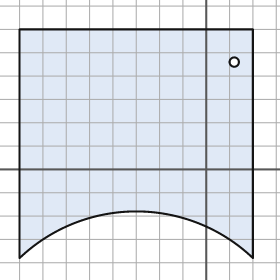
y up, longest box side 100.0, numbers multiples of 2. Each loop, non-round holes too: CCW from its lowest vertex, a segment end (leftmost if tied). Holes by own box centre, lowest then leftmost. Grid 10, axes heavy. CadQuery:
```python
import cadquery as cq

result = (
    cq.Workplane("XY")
    .moveTo(-80.0, -38.0)
    .threePointArc((-30.0, -18.0), (20.0, -38.0))
    .lineTo(20.0, 60.0)
    .lineTo(-80.0, 60.0)
    .close()
    .moveTo(12.0, 46.0)
    .circle(2.0)
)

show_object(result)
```